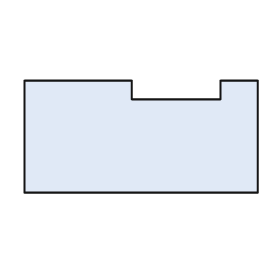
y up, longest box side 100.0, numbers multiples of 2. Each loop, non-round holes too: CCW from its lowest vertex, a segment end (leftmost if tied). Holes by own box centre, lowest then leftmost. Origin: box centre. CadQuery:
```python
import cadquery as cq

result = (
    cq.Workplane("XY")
    .moveTo(-50.0, -24.0)
    .lineTo(50.0, -24.0)
    .lineTo(50.0, 24.0)
    .lineTo(34.0, 24.0)
    .lineTo(34.0, 16.0)
    .lineTo(-4.0, 16.0)
    .lineTo(-4.0, 24.0)
    .lineTo(-50.0, 24.0)
    .close()
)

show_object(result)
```